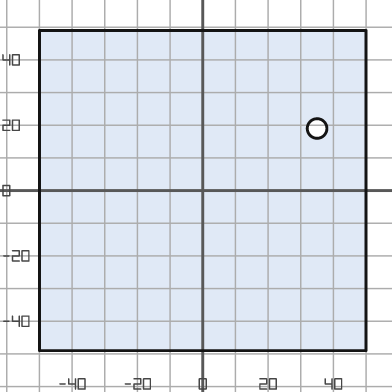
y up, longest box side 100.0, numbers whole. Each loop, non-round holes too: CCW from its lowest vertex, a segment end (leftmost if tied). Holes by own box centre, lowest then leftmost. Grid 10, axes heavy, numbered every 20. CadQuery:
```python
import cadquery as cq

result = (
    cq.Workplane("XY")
    .moveTo(-50.0, -49.0)
    .lineTo(50.0, -49.0)
    .lineTo(50.0, 49.0)
    .lineTo(-50.0, 49.0)
    .close()
    .moveTo(35.0, 19.0)
    .circle(3.0)
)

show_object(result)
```